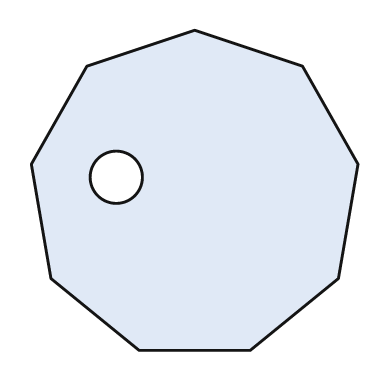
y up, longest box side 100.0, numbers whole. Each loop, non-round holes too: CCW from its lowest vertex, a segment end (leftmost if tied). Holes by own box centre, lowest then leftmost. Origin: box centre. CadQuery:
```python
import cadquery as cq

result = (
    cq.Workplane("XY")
    .moveTo(-17.0, -49.0)
    .lineTo(17.0, -49.0)
    .lineTo(44.0, -27.0)
    .lineTo(50.0, 8.0)
    .lineTo(33.0, 38.0)
    .lineTo(0.0, 49.0)
    .lineTo(-33.0, 38.0)
    .lineTo(-50.0, 8.0)
    .lineTo(-44.0, -27.0)
    .close()
    .moveTo(-24.0, 4.0)
    .circle(8.0)
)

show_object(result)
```